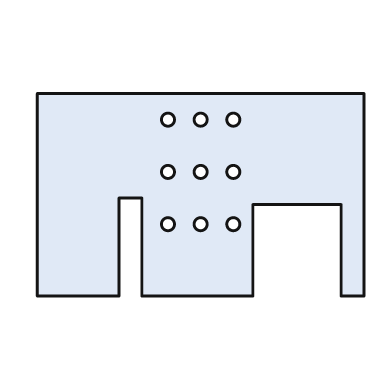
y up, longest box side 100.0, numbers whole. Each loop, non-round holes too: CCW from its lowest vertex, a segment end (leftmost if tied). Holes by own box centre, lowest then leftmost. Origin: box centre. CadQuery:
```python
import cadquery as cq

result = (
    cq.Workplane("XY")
    .moveTo(-50.0, -31.0)
    .lineTo(-25.0, -31.0)
    .lineTo(-25.0, -1.0)
    .lineTo(-18.0, -1.0)
    .lineTo(-18.0, -31.0)
    .lineTo(16.0, -31.0)
    .lineTo(16.0, -3.0)
    .lineTo(43.0, -3.0)
    .lineTo(43.0, -31.0)
    .lineTo(50.0, -31.0)
    .lineTo(50.0, 31.0)
    .lineTo(-50.0, 31.0)
    .close()
    .moveTo(-10.0, -9.0)
    .circle(2.0)
    .moveTo(0.0, -9.0)
    .circle(2.0)
    .moveTo(10.0, -9.0)
    .circle(2.0)
    .moveTo(-10.0, 7.0)
    .circle(2.0)
    .moveTo(0.0, 7.0)
    .circle(2.0)
    .moveTo(10.0, 7.0)
    .circle(2.0)
    .moveTo(-10.0, 23.0)
    .circle(2.0)
    .moveTo(0.0, 23.0)
    .circle(2.0)
    .moveTo(10.0, 23.0)
    .circle(2.0)
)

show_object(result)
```